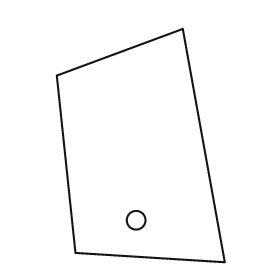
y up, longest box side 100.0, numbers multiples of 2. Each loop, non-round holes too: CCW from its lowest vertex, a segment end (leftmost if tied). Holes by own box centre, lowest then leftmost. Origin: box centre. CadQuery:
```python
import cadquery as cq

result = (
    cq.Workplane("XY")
    .moveTo(36.0, -50.0)
    .lineTo(18.0, 50.0)
    .lineTo(-36.0, 30.0)
    .lineTo(-28.0, -46.0)
    .close()
    .moveTo(-2.0, -32.0)
    .circle(4.0)
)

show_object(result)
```